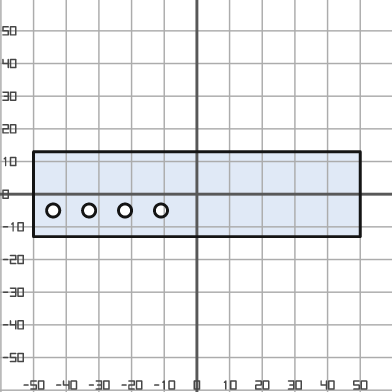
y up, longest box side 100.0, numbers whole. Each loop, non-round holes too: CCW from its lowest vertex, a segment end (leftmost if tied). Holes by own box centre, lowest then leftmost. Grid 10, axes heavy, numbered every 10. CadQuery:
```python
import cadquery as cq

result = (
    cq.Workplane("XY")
    .moveTo(-50.0, -13.0)
    .lineTo(50.0, -13.0)
    .lineTo(50.0, 13.0)
    .lineTo(-50.0, 13.0)
    .close()
    .moveTo(-44.0, -5.0)
    .circle(2.0)
    .moveTo(-33.0, -5.0)
    .circle(2.0)
    .moveTo(-22.0, -5.0)
    .circle(2.0)
    .moveTo(-11.0, -5.0)
    .circle(2.0)
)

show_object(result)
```